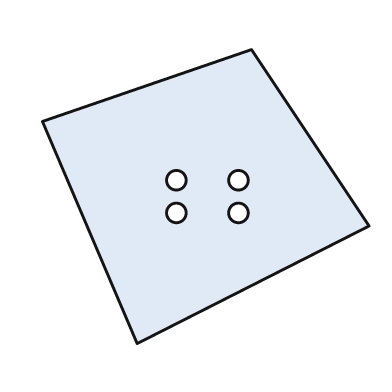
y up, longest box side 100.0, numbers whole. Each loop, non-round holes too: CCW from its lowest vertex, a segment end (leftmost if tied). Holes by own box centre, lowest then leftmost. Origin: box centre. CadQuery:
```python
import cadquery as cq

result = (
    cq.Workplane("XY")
    .moveTo(-21.0, -45.0)
    .lineTo(50.0, -9.0)
    .lineTo(14.0, 45.0)
    .lineTo(-50.0, 23.0)
    .close()
    .moveTo(-9.0, -5.0)
    .circle(3.0)
    .moveTo(10.0, -5.0)
    .circle(3.0)
    .moveTo(-9.0, 5.0)
    .circle(3.0)
    .moveTo(10.0, 5.0)
    .circle(3.0)
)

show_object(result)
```